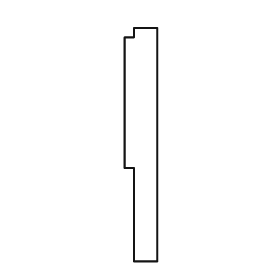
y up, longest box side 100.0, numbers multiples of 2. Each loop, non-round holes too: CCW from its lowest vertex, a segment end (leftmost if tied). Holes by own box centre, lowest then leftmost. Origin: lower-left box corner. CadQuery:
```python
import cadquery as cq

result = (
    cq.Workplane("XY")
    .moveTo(4.0, 0.0)
    .lineTo(14.0, 0.0)
    .lineTo(14.0, 100.0)
    .lineTo(4.0, 100.0)
    .lineTo(4.0, 96.0)
    .lineTo(0.0, 96.0)
    .lineTo(0.0, 40.0)
    .lineTo(4.0, 40.0)
    .close()
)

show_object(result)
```